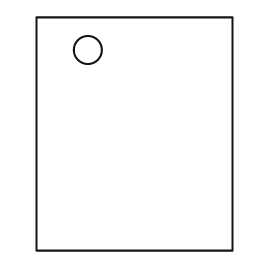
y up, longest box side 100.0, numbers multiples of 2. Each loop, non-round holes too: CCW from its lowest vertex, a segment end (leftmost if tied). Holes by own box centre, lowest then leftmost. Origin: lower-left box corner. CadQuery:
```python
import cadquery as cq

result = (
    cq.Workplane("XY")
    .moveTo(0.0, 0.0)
    .lineTo(84.0, 0.0)
    .lineTo(84.0, 100.0)
    .lineTo(0.0, 100.0)
    .close()
    .moveTo(22.0, 86.0)
    .circle(6.0)
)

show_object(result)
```